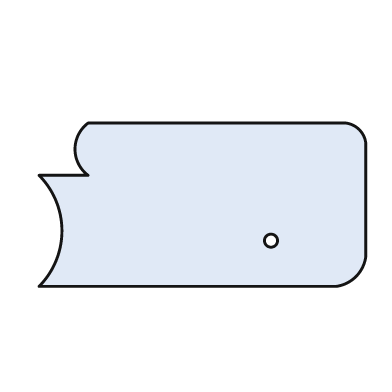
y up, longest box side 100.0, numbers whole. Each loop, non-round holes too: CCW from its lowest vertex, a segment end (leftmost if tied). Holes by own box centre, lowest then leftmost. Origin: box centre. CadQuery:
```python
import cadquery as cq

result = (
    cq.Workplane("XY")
    .moveTo(-50.0, -25.0)
    .lineTo(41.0, -25.0)
    .threePointArc((47.0, -22.0), (50.0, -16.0))
    .lineTo(50.0, 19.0)
    .threePointArc((48.0, 23.0), (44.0, 25.0))
    .lineTo(-35.0, 25.0)
    .threePointArc((-39.0, 17.0), (-35.0, 9.0))
    .lineTo(-50.0, 9.0)
    .threePointArc((-43.0, -8.0), (-50.0, -25.0))
    .close()
    .moveTo(21.0, -11.0)
    .circle(2.0)
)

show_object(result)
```